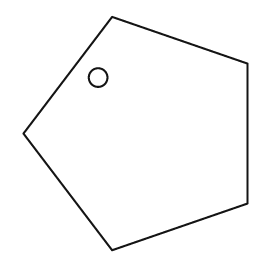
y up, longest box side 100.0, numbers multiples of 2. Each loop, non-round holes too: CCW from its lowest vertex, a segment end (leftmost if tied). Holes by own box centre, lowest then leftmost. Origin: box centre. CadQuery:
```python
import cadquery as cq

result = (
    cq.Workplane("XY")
    .moveTo(-10.0, -50.0)
    .lineTo(48.0, -30.0)
    .lineTo(48.0, 30.0)
    .lineTo(-10.0, 50.0)
    .lineTo(-48.0, 0.0)
    .close()
    .moveTo(-16.0, 24.0)
    .circle(4.0)
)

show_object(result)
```